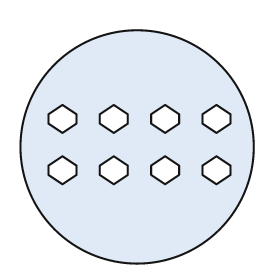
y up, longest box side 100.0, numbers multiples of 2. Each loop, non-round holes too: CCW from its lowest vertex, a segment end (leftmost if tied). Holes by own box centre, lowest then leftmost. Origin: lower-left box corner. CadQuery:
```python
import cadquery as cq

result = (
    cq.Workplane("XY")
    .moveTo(50.0, 50.0)
    .circle(50.0)
    .moveTo(18.0, 34.0)
    .lineTo(24.0, 38.0)
    .lineTo(24.0, 42.0)
    .lineTo(18.0, 46.0)
    .lineTo(12.0, 42.0)
    .lineTo(12.0, 38.0)
    .close()
    .moveTo(40.0, 34.0)
    .lineTo(46.0, 38.0)
    .lineTo(46.0, 42.0)
    .lineTo(40.0, 46.0)
    .lineTo(34.0, 42.0)
    .lineTo(34.0, 38.0)
    .close()
    .moveTo(62.0, 34.0)
    .lineTo(68.0, 38.0)
    .lineTo(68.0, 42.0)
    .lineTo(62.0, 46.0)
    .lineTo(56.0, 42.0)
    .lineTo(56.0, 38.0)
    .close()
    .moveTo(84.0, 34.0)
    .lineTo(90.0, 38.0)
    .lineTo(90.0, 42.0)
    .lineTo(84.0, 46.0)
    .lineTo(78.0, 42.0)
    .lineTo(78.0, 38.0)
    .close()
    .moveTo(18.0, 56.0)
    .lineTo(24.0, 60.0)
    .lineTo(24.0, 64.0)
    .lineTo(18.0, 68.0)
    .lineTo(12.0, 64.0)
    .lineTo(12.0, 60.0)
    .close()
    .moveTo(40.0, 56.0)
    .lineTo(46.0, 60.0)
    .lineTo(46.0, 64.0)
    .lineTo(40.0, 68.0)
    .lineTo(34.0, 64.0)
    .lineTo(34.0, 60.0)
    .close()
    .moveTo(62.0, 56.0)
    .lineTo(68.0, 60.0)
    .lineTo(68.0, 64.0)
    .lineTo(62.0, 68.0)
    .lineTo(56.0, 64.0)
    .lineTo(56.0, 60.0)
    .close()
    .moveTo(84.0, 56.0)
    .lineTo(90.0, 60.0)
    .lineTo(90.0, 64.0)
    .lineTo(84.0, 68.0)
    .lineTo(78.0, 64.0)
    .lineTo(78.0, 60.0)
    .close()
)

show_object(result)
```